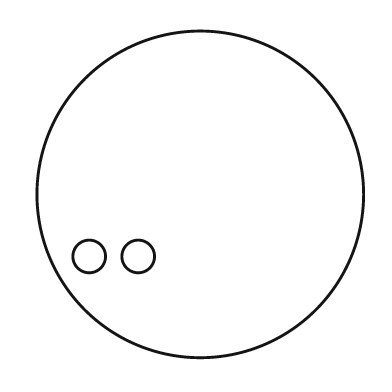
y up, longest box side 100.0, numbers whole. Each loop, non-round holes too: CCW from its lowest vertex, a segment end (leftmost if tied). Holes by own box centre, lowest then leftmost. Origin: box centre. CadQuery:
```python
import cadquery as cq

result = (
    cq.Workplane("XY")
    .moveTo(0.0, 0.0)
    .circle(50.0)
    .moveTo(-34.0, -19.0)
    .circle(5.0)
    .moveTo(-19.0, -19.0)
    .circle(5.0)
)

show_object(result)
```